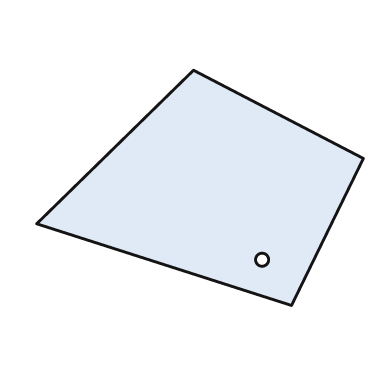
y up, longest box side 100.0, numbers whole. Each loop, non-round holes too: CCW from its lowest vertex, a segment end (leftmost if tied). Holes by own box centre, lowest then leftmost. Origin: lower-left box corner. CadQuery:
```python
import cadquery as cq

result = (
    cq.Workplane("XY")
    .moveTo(78.0, 0.0)
    .lineTo(100.0, 45.0)
    .lineTo(48.0, 72.0)
    .lineTo(0.0, 25.0)
    .close()
    .moveTo(69.0, 14.0)
    .circle(2.0)
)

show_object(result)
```